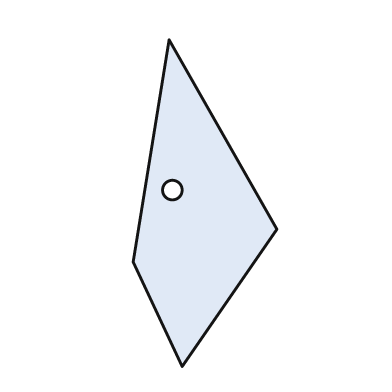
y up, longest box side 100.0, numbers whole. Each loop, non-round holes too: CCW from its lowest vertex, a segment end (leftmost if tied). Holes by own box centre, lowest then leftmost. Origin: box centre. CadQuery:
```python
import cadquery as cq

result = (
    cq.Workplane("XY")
    .moveTo(-7.0, -50.0)
    .lineTo(22.0, -8.0)
    .lineTo(-11.0, 50.0)
    .lineTo(-22.0, -18.0)
    .close()
    .moveTo(-10.0, 4.0)
    .circle(3.0)
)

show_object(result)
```